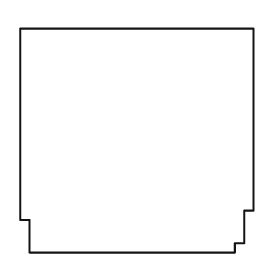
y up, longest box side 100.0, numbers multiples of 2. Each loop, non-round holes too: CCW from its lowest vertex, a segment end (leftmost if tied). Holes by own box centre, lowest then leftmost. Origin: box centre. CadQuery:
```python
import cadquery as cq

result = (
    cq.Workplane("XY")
    .moveTo(-46.0, -48.0)
    .lineTo(42.0, -48.0)
    .lineTo(42.0, -44.0)
    .lineTo(46.0, -44.0)
    .lineTo(46.0, -30.0)
    .lineTo(50.0, -30.0)
    .lineTo(50.0, 48.0)
    .lineTo(-50.0, 48.0)
    .lineTo(-50.0, -34.0)
    .lineTo(-46.0, -34.0)
    .close()
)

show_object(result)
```